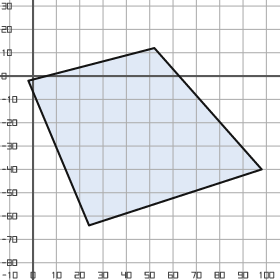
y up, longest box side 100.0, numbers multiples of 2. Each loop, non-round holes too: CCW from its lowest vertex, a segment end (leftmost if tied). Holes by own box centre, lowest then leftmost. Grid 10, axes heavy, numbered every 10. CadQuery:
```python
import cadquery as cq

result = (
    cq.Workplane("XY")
    .moveTo(24.0, -64.0)
    .lineTo(98.0, -40.0)
    .lineTo(52.0, 12.0)
    .lineTo(-2.0, -2.0)
    .close()
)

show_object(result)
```